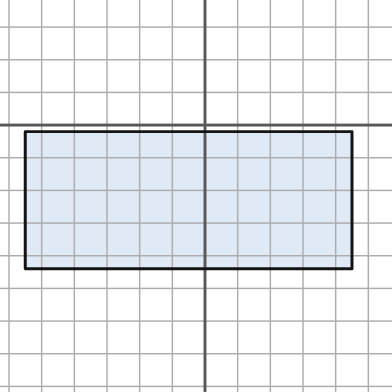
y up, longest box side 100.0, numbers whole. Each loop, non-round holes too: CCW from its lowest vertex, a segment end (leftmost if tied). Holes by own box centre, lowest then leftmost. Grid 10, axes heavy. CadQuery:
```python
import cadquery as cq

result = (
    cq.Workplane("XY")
    .moveTo(-55.0, -44.0)
    .lineTo(45.0, -44.0)
    .lineTo(45.0, -2.0)
    .lineTo(-55.0, -2.0)
    .close()
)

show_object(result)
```